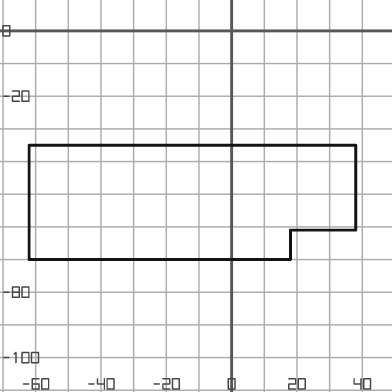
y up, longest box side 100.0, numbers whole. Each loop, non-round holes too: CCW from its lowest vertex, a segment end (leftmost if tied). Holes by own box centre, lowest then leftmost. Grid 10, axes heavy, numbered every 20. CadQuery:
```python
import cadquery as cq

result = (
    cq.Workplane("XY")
    .moveTo(-62.0, -70.0)
    .lineTo(18.0, -70.0)
    .lineTo(18.0, -61.0)
    .lineTo(38.0, -61.0)
    .lineTo(38.0, -35.0)
    .lineTo(-62.0, -35.0)
    .close()
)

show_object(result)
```